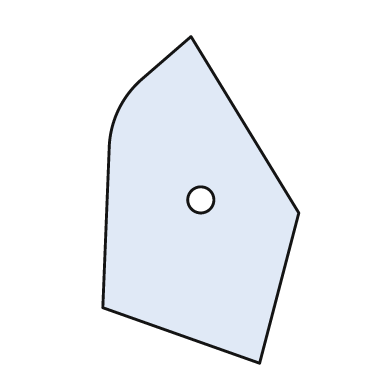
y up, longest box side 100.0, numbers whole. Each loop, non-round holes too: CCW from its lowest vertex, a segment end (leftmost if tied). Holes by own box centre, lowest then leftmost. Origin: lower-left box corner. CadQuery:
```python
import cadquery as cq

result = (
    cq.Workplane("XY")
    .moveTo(48.0, 0.0)
    .lineTo(60.0, 46.0)
    .lineTo(27.0, 100.0)
    .lineTo(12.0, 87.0)
    .threePointArc((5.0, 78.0), (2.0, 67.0))
    .lineTo(0.0, 17.0)
    .close()
    .moveTo(30.0, 50.0)
    .circle(4.0)
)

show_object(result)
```